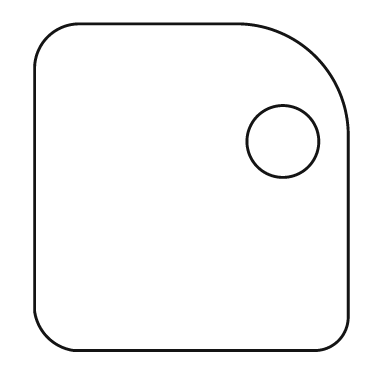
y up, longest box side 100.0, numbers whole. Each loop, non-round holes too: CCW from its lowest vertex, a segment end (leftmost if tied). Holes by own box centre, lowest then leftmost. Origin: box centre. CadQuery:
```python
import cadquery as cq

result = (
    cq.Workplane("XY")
    .moveTo(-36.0, -50.0)
    .lineTo(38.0, -50.0)
    .threePointArc((45.0, -47.0), (48.0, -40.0))
    .lineTo(48.0, 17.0)
    .threePointArc((38.0, 40.0), (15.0, 50.0))
    .lineTo(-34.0, 50.0)
    .threePointArc((-44.0, 46.0), (-48.0, 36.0))
    .lineTo(-48.0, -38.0)
    .threePointArc((-44.0, -46.0), (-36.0, -50.0))
    .close()
    .moveTo(28.0, 14.0)
    .circle(11.0)
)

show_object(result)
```